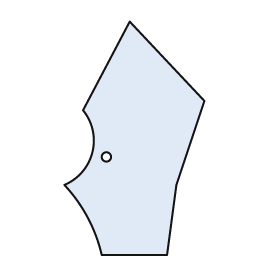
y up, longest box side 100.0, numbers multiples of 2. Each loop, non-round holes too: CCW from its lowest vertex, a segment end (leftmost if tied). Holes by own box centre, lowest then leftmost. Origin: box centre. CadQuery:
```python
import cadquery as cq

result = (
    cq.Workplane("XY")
    .moveTo(-14.0, -50.0)
    .lineTo(14.0, -50.0)
    .lineTo(18.0, -20.0)
    .lineTo(30.0, 16.0)
    .lineTo(-2.0, 50.0)
    .lineTo(-22.0, 12.0)
    .threePointArc((-18.0, -6.0), (-30.0, -20.0))
    .threePointArc((-20.0, -34.0), (-14.0, -50.0))
    .close()
    .moveTo(-12.0, -8.0)
    .circle(2.0)
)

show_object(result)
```